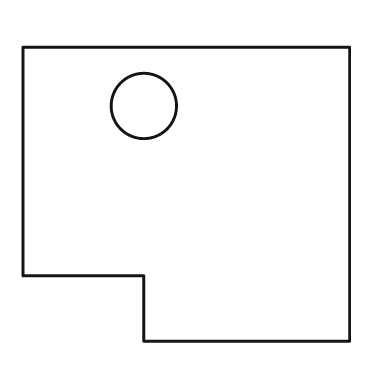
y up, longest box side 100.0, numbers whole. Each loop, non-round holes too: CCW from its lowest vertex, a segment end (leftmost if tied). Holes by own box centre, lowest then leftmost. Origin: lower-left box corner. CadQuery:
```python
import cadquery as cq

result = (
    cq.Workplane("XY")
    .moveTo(37.0, 0.0)
    .lineTo(100.0, 0.0)
    .lineTo(100.0, 90.0)
    .lineTo(0.0, 90.0)
    .lineTo(0.0, 20.0)
    .lineTo(37.0, 20.0)
    .close()
    .moveTo(37.0, 72.0)
    .circle(10.0)
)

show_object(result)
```